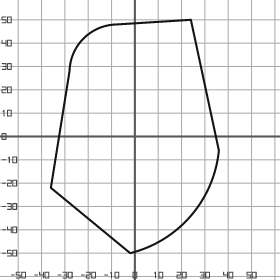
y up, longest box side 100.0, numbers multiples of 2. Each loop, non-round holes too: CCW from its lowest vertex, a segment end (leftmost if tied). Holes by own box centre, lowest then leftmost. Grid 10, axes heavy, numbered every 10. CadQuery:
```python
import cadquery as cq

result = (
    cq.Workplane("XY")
    .moveTo(-2.0, -50.0)
    .threePointArc((24.0, -34.0), (36.0, -6.0))
    .lineTo(24.0, 50.0)
    .lineTo(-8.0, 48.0)
    .threePointArc((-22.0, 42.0), (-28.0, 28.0))
    .lineTo(-36.0, -22.0)
    .close()
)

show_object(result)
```